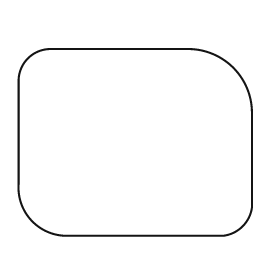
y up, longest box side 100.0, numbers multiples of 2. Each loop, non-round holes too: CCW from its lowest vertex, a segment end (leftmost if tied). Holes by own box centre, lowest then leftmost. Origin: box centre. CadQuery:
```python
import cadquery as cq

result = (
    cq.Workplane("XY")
    .moveTo(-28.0, -40.0)
    .lineTo(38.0, -40.0)
    .threePointArc((46.0, -36.0), (50.0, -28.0))
    .lineTo(50.0, 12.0)
    .threePointArc((42.0, 32.0), (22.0, 40.0))
    .lineTo(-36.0, 40.0)
    .threePointArc((-46.0, 36.0), (-50.0, 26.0))
    .lineTo(-50.0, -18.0)
    .threePointArc((-44.0, -34.0), (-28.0, -40.0))
    .close()
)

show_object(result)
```